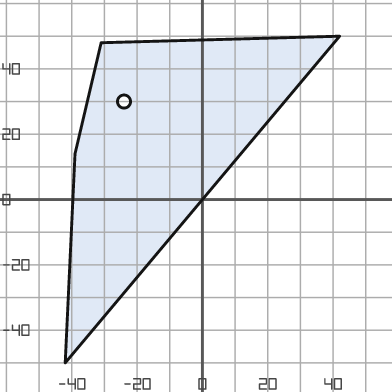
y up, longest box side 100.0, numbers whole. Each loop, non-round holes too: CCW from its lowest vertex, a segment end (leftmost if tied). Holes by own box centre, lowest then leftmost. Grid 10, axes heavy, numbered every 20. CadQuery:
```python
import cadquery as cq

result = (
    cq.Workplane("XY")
    .moveTo(-42.0, -50.0)
    .lineTo(42.0, 50.0)
    .lineTo(-31.0, 48.0)
    .lineTo(-39.0, 14.0)
    .close()
    .moveTo(-24.0, 30.0)
    .circle(2.0)
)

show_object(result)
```